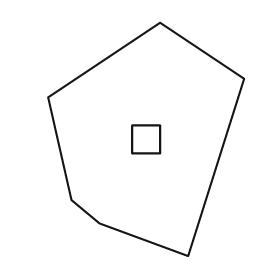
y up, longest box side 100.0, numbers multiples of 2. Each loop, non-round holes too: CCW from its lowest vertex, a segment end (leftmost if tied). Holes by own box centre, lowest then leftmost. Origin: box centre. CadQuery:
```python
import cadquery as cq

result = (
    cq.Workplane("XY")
    .moveTo(18.0, -50.0)
    .lineTo(42.0, 26.0)
    .lineTo(6.0, 50.0)
    .lineTo(-42.0, 18.0)
    .lineTo(-32.0, -26.0)
    .lineTo(-20.0, -36.0)
    .close()
    .moveTo(-6.0, -6.0)
    .lineTo(6.0, -6.0)
    .lineTo(6.0, 6.0)
    .lineTo(-6.0, 6.0)
    .close()
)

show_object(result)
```